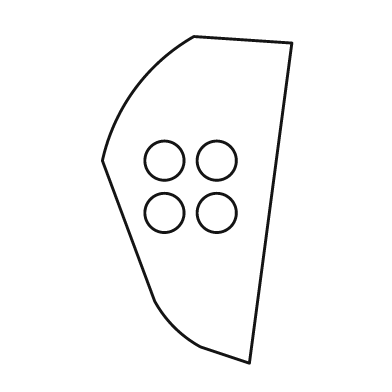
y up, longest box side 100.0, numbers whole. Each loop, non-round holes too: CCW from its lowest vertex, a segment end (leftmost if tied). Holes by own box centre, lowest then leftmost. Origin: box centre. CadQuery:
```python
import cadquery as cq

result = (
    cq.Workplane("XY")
    .moveTo(16.0, -50.0)
    .lineTo(29.0, 48.0)
    .lineTo(-1.0, 50.0)
    .threePointArc((-19.0, 34.0), (-29.0, 12.0))
    .lineTo(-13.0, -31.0)
    .threePointArc((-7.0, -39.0), (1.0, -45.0))
    .close()
    .moveTo(-10.0, -4.0)
    .circle(6.0)
    .moveTo(6.0, -4.0)
    .circle(6.0)
    .moveTo(-10.0, 12.0)
    .circle(6.0)
    .moveTo(6.0, 12.0)
    .circle(6.0)
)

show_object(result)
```